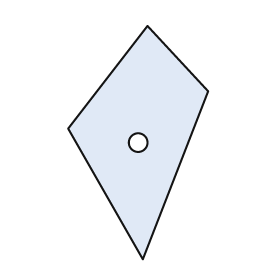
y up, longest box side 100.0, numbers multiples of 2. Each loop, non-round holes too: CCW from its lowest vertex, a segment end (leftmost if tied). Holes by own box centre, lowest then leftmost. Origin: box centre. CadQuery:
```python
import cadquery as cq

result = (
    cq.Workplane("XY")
    .moveTo(2.0, -50.0)
    .lineTo(30.0, 22.0)
    .lineTo(4.0, 50.0)
    .lineTo(-30.0, 6.0)
    .close()
    .moveTo(0.0, 0.0)
    .circle(4.0)
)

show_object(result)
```